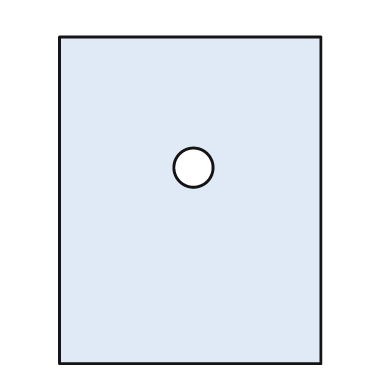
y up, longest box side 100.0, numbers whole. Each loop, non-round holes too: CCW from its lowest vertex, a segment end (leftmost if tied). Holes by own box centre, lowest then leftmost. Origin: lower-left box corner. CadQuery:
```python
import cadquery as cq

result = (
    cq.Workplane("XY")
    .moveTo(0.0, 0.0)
    .lineTo(80.0, 0.0)
    .lineTo(80.0, 100.0)
    .lineTo(0.0, 100.0)
    .close()
    .moveTo(41.0, 60.0)
    .circle(6.0)
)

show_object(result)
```